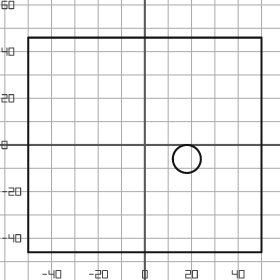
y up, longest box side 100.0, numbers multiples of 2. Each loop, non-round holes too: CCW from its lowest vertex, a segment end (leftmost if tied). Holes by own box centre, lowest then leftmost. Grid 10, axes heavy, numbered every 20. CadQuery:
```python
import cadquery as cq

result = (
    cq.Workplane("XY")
    .moveTo(-50.0, -46.0)
    .lineTo(50.0, -46.0)
    .lineTo(50.0, 46.0)
    .lineTo(-50.0, 46.0)
    .close()
    .moveTo(18.0, -6.0)
    .circle(6.0)
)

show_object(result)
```